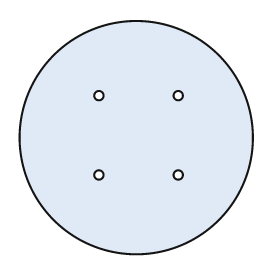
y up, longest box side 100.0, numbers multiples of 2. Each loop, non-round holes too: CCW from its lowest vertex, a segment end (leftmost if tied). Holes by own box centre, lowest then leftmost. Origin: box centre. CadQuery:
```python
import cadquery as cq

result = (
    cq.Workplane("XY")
    .moveTo(0.0, 0.0)
    .circle(50.0)
    .moveTo(-16.0, -16.0)
    .circle(2.0)
    .moveTo(18.0, -16.0)
    .circle(2.0)
    .moveTo(-16.0, 18.0)
    .circle(2.0)
    .moveTo(18.0, 18.0)
    .circle(2.0)
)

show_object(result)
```